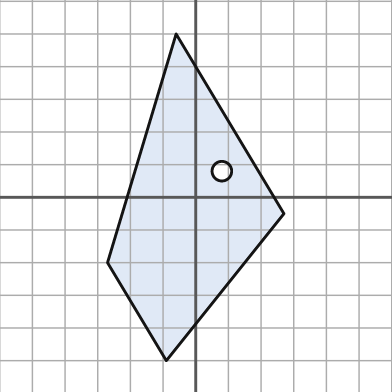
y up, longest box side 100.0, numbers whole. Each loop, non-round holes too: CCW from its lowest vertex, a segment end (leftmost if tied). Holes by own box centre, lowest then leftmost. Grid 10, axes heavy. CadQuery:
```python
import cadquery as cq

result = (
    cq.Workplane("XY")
    .moveTo(-9.0, -50.0)
    .lineTo(27.0, -5.0)
    .lineTo(-6.0, 50.0)
    .lineTo(-27.0, -20.0)
    .close()
    .moveTo(8.0, 8.0)
    .circle(3.0)
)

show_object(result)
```